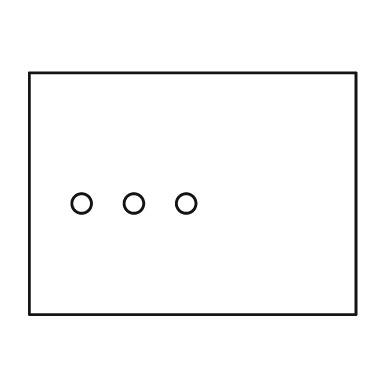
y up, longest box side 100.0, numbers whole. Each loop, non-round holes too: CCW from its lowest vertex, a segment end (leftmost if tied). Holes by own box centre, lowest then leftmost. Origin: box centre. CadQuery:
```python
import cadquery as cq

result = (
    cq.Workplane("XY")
    .moveTo(-50.0, -37.0)
    .lineTo(50.0, -37.0)
    .lineTo(50.0, 37.0)
    .lineTo(-50.0, 37.0)
    .close()
    .moveTo(-34.0, -3.0)
    .circle(3.0)
    .moveTo(-18.0, -3.0)
    .circle(3.0)
    .moveTo(-2.0, -3.0)
    .circle(3.0)
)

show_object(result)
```